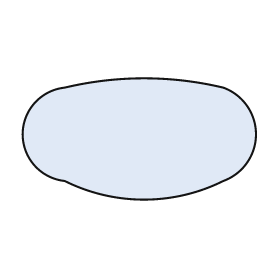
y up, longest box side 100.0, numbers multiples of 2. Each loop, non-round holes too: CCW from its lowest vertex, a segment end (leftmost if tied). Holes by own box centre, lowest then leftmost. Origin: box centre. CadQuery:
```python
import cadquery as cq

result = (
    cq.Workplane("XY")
    .moveTo(-32.0, -18.0)
    .threePointArc((2.0, -26.0), (36.0, -18.0))
    .threePointArc((50.0, 2.0), (36.0, 22.0))
    .threePointArc((2.0, 26.0), (-32.0, 22.0))
    .threePointArc((-50.0, 2.0), (-32.0, -18.0))
    .close()
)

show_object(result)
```